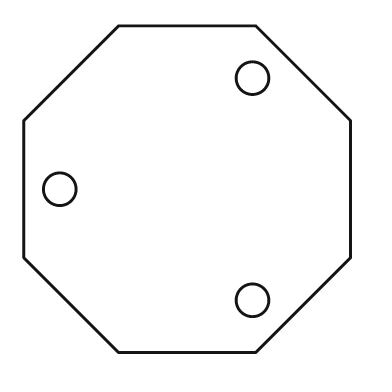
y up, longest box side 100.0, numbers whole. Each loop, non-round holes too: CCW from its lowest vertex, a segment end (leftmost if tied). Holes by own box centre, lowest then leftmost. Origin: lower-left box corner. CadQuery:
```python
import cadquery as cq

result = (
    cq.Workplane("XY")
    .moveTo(29.0, 0.0)
    .lineTo(71.0, 0.0)
    .lineTo(100.0, 29.0)
    .lineTo(100.0, 71.0)
    .lineTo(71.0, 100.0)
    .lineTo(29.0, 100.0)
    .lineTo(0.0, 71.0)
    .lineTo(0.0, 29.0)
    .close()
    .moveTo(70.0, 16.0)
    .circle(5.0)
    .moveTo(11.0, 50.0)
    .circle(5.0)
    .moveTo(70.0, 84.0)
    .circle(5.0)
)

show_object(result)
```